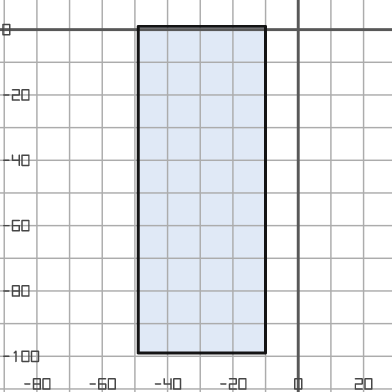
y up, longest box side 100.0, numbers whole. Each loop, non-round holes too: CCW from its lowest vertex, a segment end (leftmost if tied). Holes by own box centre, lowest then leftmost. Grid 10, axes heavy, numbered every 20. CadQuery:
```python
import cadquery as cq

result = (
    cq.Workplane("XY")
    .moveTo(-49.0, -99.0)
    .lineTo(-10.0, -99.0)
    .lineTo(-10.0, 1.0)
    .lineTo(-49.0, 1.0)
    .close()
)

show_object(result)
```